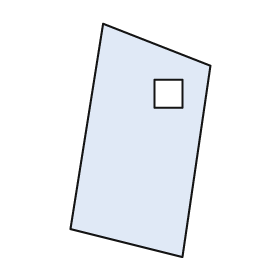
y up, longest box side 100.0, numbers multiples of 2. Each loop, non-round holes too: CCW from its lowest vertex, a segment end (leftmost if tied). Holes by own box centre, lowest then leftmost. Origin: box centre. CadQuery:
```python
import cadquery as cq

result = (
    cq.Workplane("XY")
    .moveTo(18.0, -50.0)
    .lineTo(30.0, 32.0)
    .lineTo(-16.0, 50.0)
    .lineTo(-30.0, -38.0)
    .close()
    .moveTo(6.0, 14.0)
    .lineTo(18.0, 14.0)
    .lineTo(18.0, 26.0)
    .lineTo(6.0, 26.0)
    .close()
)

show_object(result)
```